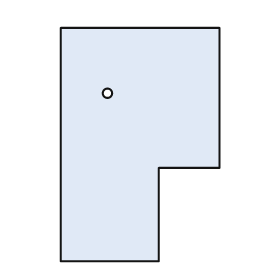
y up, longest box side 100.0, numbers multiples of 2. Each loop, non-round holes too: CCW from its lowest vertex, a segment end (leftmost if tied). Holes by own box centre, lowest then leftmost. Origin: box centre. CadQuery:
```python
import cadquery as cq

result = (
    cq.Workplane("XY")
    .moveTo(-34.0, -50.0)
    .lineTo(8.0, -50.0)
    .lineTo(8.0, -10.0)
    .lineTo(34.0, -10.0)
    .lineTo(34.0, 50.0)
    .lineTo(-34.0, 50.0)
    .close()
    .moveTo(-14.0, 22.0)
    .circle(2.0)
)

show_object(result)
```